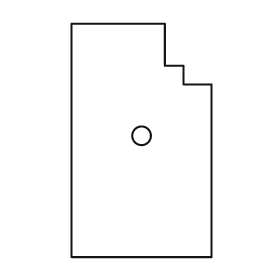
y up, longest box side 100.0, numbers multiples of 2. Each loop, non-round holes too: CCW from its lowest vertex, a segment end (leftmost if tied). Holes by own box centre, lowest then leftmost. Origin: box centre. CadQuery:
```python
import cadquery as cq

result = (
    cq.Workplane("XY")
    .moveTo(-30.0, -50.0)
    .lineTo(30.0, -50.0)
    .lineTo(30.0, 24.0)
    .lineTo(18.0, 24.0)
    .lineTo(18.0, 32.0)
    .lineTo(10.0, 32.0)
    .lineTo(10.0, 50.0)
    .lineTo(-30.0, 50.0)
    .close()
    .moveTo(0.0, 2.0)
    .circle(4.0)
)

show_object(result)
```